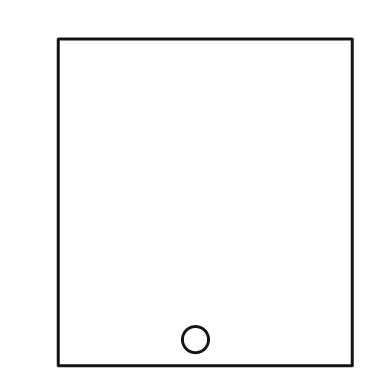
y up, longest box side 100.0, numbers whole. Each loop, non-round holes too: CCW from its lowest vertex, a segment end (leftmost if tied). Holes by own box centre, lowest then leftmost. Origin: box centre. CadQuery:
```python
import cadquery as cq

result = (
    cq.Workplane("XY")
    .moveTo(-45.0, -50.0)
    .lineTo(45.0, -50.0)
    .lineTo(45.0, 50.0)
    .lineTo(-45.0, 50.0)
    .close()
    .moveTo(-3.0, -42.0)
    .circle(4.0)
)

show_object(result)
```